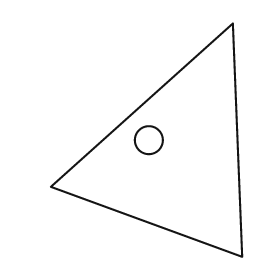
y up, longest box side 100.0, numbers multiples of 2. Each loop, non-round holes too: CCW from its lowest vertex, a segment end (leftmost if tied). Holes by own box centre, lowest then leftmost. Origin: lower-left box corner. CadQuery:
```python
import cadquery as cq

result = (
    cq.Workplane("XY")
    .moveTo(82.0, 0.0)
    .lineTo(78.0, 100.0)
    .lineTo(0.0, 30.0)
    .close()
    .moveTo(42.0, 50.0)
    .circle(6.0)
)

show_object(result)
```